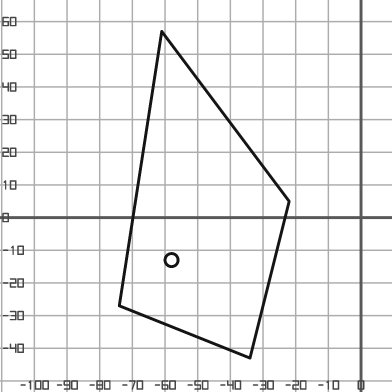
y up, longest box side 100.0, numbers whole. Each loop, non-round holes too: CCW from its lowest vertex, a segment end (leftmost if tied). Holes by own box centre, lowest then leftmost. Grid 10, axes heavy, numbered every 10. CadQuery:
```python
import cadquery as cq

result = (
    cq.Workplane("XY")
    .moveTo(-34.0, -43.0)
    .lineTo(-22.0, 5.0)
    .lineTo(-61.0, 57.0)
    .lineTo(-74.0, -27.0)
    .close()
    .moveTo(-58.0, -13.0)
    .circle(2.0)
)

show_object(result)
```